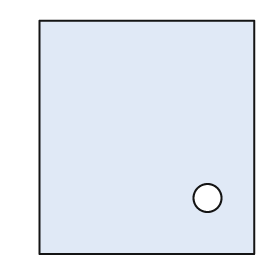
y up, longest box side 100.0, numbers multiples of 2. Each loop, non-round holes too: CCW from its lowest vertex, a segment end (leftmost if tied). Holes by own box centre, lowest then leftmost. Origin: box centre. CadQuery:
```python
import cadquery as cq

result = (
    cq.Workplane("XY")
    .moveTo(-46.0, -50.0)
    .lineTo(46.0, -50.0)
    .lineTo(46.0, 50.0)
    .lineTo(-46.0, 50.0)
    .close()
    .moveTo(26.0, -26.0)
    .circle(6.0)
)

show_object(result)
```